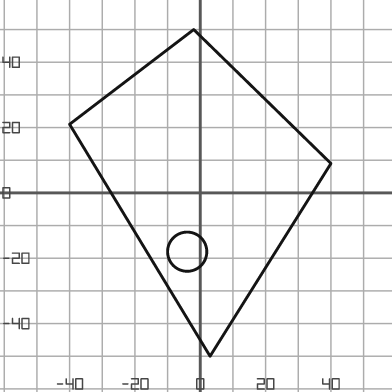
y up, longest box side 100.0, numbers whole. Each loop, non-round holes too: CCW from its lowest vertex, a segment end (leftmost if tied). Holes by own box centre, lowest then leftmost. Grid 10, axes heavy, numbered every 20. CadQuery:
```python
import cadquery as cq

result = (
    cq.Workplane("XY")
    .moveTo(3.0, -50.0)
    .lineTo(40.0, 9.0)
    .lineTo(-2.0, 50.0)
    .lineTo(-40.0, 21.0)
    .close()
    .moveTo(-4.0, -18.0)
    .circle(6.0)
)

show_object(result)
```